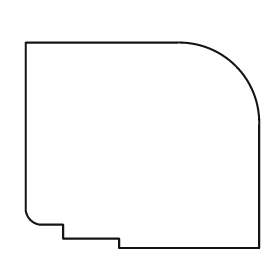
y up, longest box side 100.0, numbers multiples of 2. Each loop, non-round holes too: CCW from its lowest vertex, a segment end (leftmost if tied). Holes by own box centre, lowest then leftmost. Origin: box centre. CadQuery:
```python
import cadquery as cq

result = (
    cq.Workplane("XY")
    .moveTo(-10.0, -44.0)
    .lineTo(50.0, -44.0)
    .lineTo(50.0, 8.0)
    .threePointArc((40.0, 34.0), (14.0, 44.0))
    .lineTo(-50.0, 44.0)
    .lineTo(-50.0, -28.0)
    .threePointArc((-48.0, -32.0), (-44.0, -34.0))
    .lineTo(-34.0, -34.0)
    .lineTo(-34.0, -40.0)
    .lineTo(-10.0, -40.0)
    .close()
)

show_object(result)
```